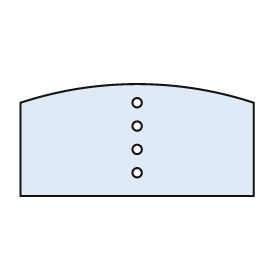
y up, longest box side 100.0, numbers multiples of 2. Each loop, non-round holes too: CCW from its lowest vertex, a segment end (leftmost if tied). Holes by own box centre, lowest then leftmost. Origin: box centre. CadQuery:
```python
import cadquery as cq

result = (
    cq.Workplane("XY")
    .moveTo(-50.0, -24.0)
    .lineTo(50.0, -24.0)
    .lineTo(50.0, 16.0)
    .threePointArc((0.0, 24.0), (-50.0, 16.0))
    .close()
    .moveTo(0.0, -14.0)
    .circle(2.0)
    .moveTo(0.0, -4.0)
    .circle(2.0)
    .moveTo(0.0, 6.0)
    .circle(2.0)
    .moveTo(0.0, 16.0)
    .circle(2.0)
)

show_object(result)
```